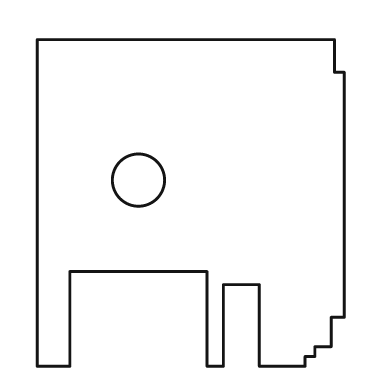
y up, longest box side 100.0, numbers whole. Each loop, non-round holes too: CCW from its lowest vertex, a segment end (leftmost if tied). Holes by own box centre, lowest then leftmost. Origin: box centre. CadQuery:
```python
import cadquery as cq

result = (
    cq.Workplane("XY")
    .moveTo(-47.0, -50.0)
    .lineTo(-37.0, -50.0)
    .lineTo(-37.0, -21.0)
    .lineTo(5.0, -21.0)
    .lineTo(5.0, -50.0)
    .lineTo(10.0, -50.0)
    .lineTo(10.0, -25.0)
    .lineTo(21.0, -25.0)
    .lineTo(21.0, -50.0)
    .lineTo(35.0, -50.0)
    .lineTo(35.0, -47.0)
    .lineTo(38.0, -47.0)
    .lineTo(38.0, -44.0)
    .lineTo(43.0, -44.0)
    .lineTo(43.0, -35.0)
    .lineTo(47.0, -35.0)
    .lineTo(47.0, 40.0)
    .lineTo(44.0, 40.0)
    .lineTo(44.0, 50.0)
    .lineTo(-47.0, 50.0)
    .close()
    .moveTo(-16.0, 7.0)
    .circle(8.0)
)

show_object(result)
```